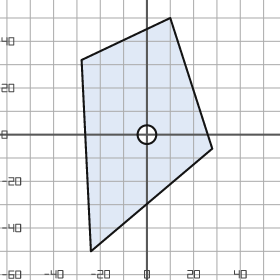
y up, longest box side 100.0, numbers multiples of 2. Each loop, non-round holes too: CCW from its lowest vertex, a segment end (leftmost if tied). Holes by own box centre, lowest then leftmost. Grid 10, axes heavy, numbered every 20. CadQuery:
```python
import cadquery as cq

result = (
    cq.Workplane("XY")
    .moveTo(-24.0, -50.0)
    .lineTo(28.0, -6.0)
    .lineTo(10.0, 50.0)
    .lineTo(-28.0, 32.0)
    .close()
    .moveTo(0.0, 0.0)
    .circle(4.0)
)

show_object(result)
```